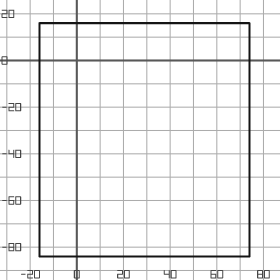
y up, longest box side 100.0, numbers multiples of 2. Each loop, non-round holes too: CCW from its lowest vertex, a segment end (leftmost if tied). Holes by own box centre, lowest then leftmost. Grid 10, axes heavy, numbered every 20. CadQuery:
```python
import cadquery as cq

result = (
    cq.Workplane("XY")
    .moveTo(-16.0, -84.0)
    .lineTo(74.0, -84.0)
    .lineTo(74.0, 16.0)
    .lineTo(-16.0, 16.0)
    .close()
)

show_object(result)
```